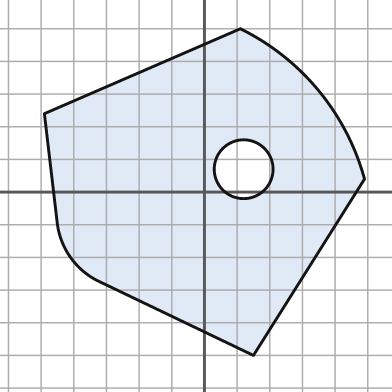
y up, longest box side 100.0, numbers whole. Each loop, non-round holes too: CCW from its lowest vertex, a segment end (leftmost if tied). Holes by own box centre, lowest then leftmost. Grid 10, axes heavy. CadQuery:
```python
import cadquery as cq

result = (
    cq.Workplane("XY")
    .moveTo(15.0, -50.0)
    .lineTo(49.0, 4.0)
    .threePointArc((35.0, 31.0), (11.0, 50.0))
    .lineTo(-49.0, 24.0)
    .lineTo(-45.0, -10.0)
    .threePointArc((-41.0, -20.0), (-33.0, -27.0))
    .close()
    .moveTo(12.0, 7.0)
    .circle(9.0)
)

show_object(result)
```